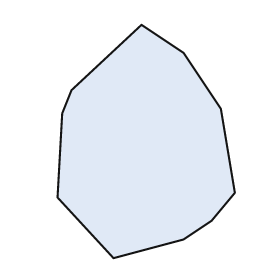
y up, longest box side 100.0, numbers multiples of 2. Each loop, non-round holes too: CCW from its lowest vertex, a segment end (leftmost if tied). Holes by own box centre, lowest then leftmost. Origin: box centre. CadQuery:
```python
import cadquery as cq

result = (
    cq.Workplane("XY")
    .moveTo(-14.0, -50.0)
    .lineTo(16.0, -42.0)
    .lineTo(28.0, -34.0)
    .lineTo(38.0, -22.0)
    .lineTo(32.0, 14.0)
    .lineTo(16.0, 38.0)
    .lineTo(-2.0, 50.0)
    .lineTo(-32.0, 22.0)
    .lineTo(-36.0, 12.0)
    .lineTo(-38.0, -24.0)
    .close()
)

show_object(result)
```